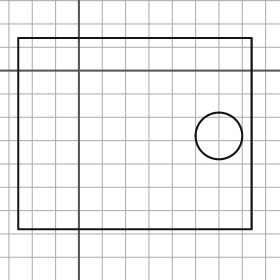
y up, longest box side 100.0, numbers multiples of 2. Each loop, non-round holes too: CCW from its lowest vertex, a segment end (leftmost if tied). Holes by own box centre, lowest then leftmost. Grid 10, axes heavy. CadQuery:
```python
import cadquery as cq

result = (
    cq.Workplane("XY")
    .moveTo(-26.0, -68.0)
    .lineTo(74.0, -68.0)
    .lineTo(74.0, 14.0)
    .lineTo(-26.0, 14.0)
    .close()
    .moveTo(60.0, -28.0)
    .circle(10.0)
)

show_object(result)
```